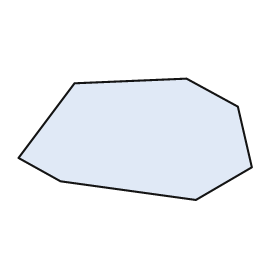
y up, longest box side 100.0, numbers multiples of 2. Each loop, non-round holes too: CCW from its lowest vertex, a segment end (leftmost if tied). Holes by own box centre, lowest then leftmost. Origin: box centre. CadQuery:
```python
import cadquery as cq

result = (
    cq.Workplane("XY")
    .moveTo(26.0, -26.0)
    .lineTo(50.0, -12.0)
    .lineTo(44.0, 14.0)
    .lineTo(22.0, 26.0)
    .lineTo(-26.0, 24.0)
    .lineTo(-50.0, -8.0)
    .lineTo(-32.0, -18.0)
    .close()
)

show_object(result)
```